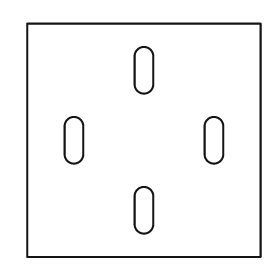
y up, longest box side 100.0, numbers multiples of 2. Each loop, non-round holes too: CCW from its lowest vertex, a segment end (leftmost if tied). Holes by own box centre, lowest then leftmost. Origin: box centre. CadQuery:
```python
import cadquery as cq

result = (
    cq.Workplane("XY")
    .moveTo(-50.0, -50.0)
    .lineTo(50.0, -50.0)
    .lineTo(50.0, 50.0)
    .lineTo(-50.0, 50.0)
    .close()
    .moveTo(-4.0, -36.0)
    .threePointArc((0.0, -40.0), (4.0, -36.0))
    .lineTo(4.0, -24.0)
    .threePointArc((0.0, -20.0), (-4.0, -24.0))
    .close()
    .moveTo(-34.0, -6.0)
    .threePointArc((-30.0, -10.0), (-26.0, -6.0))
    .lineTo(-26.0, 6.0)
    .threePointArc((-30.0, 10.0), (-34.0, 6.0))
    .close()
    .moveTo(26.0, -6.0)
    .threePointArc((30.0, -10.0), (34.0, -6.0))
    .lineTo(34.0, 6.0)
    .threePointArc((30.0, 10.0), (26.0, 6.0))
    .close()
    .moveTo(-4.0, 24.0)
    .threePointArc((0.0, 20.0), (4.0, 24.0))
    .lineTo(4.0, 36.0)
    .threePointArc((0.0, 40.0), (-4.0, 36.0))
    .close()
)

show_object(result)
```